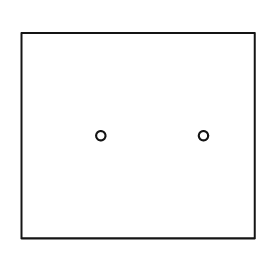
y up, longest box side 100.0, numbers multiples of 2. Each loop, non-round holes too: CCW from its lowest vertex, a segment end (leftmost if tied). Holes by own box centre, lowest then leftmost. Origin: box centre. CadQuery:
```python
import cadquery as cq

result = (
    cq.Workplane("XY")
    .moveTo(-50.0, -44.0)
    .lineTo(50.0, -44.0)
    .lineTo(50.0, 44.0)
    .lineTo(-50.0, 44.0)
    .close()
    .moveTo(-16.0, 0.0)
    .circle(2.0)
    .moveTo(28.0, 0.0)
    .circle(2.0)
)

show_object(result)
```